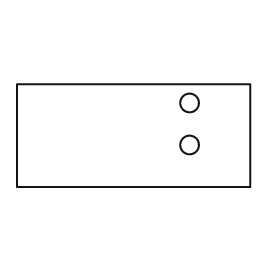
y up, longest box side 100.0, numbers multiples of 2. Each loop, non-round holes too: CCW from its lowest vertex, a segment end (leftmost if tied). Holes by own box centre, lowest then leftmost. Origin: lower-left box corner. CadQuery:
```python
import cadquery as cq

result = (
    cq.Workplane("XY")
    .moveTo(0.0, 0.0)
    .lineTo(100.0, 0.0)
    .lineTo(100.0, 44.0)
    .lineTo(0.0, 44.0)
    .close()
    .moveTo(74.0, 18.0)
    .circle(4.0)
    .moveTo(74.0, 36.0)
    .circle(4.0)
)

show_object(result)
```